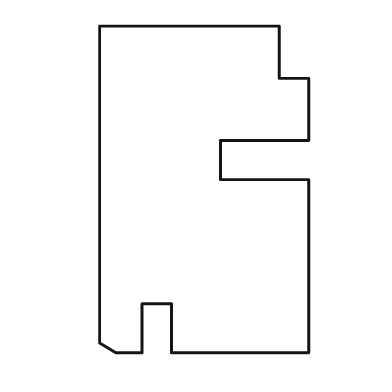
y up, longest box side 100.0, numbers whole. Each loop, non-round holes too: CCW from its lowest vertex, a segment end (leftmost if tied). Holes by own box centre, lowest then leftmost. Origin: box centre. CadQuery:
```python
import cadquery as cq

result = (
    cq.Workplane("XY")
    .moveTo(-27.0, -50.0)
    .lineTo(-19.0, -50.0)
    .lineTo(-19.0, -35.0)
    .lineTo(-10.0, -35.0)
    .lineTo(-10.0, -50.0)
    .lineTo(32.0, -50.0)
    .lineTo(32.0, 3.0)
    .lineTo(5.0, 3.0)
    .lineTo(5.0, 15.0)
    .lineTo(32.0, 15.0)
    .lineTo(32.0, 34.0)
    .lineTo(23.0, 34.0)
    .lineTo(23.0, 50.0)
    .lineTo(-32.0, 50.0)
    .lineTo(-32.0, -47.0)
    .close()
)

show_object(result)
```